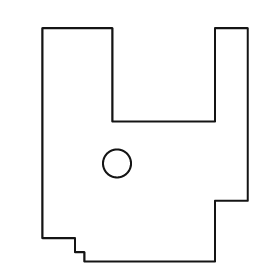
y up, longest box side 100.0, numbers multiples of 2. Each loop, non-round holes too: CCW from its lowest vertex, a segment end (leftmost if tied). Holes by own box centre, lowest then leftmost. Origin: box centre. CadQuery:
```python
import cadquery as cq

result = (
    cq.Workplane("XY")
    .moveTo(-26.0, -50.0)
    .lineTo(30.0, -50.0)
    .lineTo(30.0, -24.0)
    .lineTo(44.0, -24.0)
    .lineTo(44.0, 50.0)
    .lineTo(30.0, 50.0)
    .lineTo(30.0, 10.0)
    .lineTo(-14.0, 10.0)
    .lineTo(-14.0, 50.0)
    .lineTo(-44.0, 50.0)
    .lineTo(-44.0, -40.0)
    .lineTo(-30.0, -40.0)
    .lineTo(-30.0, -46.0)
    .lineTo(-26.0, -46.0)
    .close()
    .moveTo(-12.0, -8.0)
    .circle(6.0)
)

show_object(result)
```